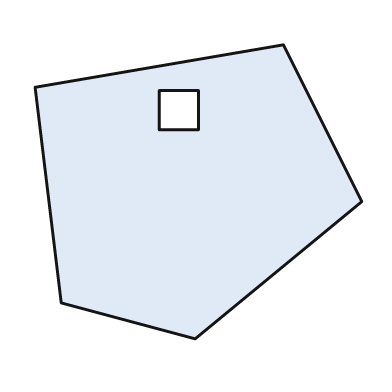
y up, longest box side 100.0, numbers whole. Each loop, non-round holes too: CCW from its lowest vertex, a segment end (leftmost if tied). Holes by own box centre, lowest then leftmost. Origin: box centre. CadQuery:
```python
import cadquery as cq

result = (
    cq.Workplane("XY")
    .moveTo(-1.0, -45.0)
    .lineTo(50.0, -3.0)
    .lineTo(26.0, 45.0)
    .lineTo(-50.0, 32.0)
    .lineTo(-42.0, -34.0)
    .close()
    .moveTo(-12.0, 19.0)
    .lineTo(0.0, 19.0)
    .lineTo(0.0, 31.0)
    .lineTo(-12.0, 31.0)
    .close()
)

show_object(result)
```